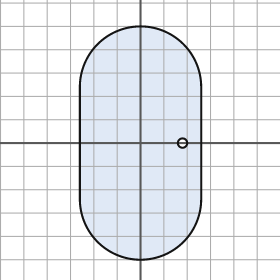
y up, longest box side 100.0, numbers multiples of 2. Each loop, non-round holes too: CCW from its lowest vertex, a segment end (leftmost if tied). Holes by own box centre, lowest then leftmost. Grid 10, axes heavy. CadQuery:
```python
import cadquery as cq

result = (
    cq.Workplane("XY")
    .moveTo(-26.0, -24.0)
    .threePointArc((0.0, -50.0), (26.0, -24.0))
    .lineTo(26.0, 24.0)
    .threePointArc((0.0, 50.0), (-26.0, 24.0))
    .close()
    .moveTo(18.0, 0.0)
    .circle(2.0)
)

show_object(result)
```